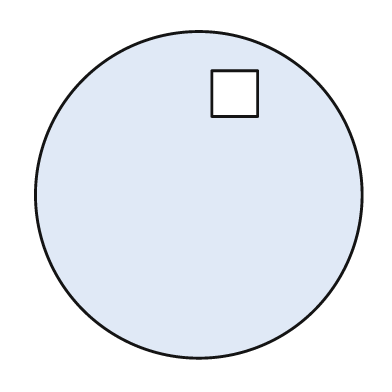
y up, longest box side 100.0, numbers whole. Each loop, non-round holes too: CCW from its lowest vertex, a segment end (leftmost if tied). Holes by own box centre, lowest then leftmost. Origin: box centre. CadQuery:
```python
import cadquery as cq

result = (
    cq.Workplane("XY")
    .moveTo(0.0, 0.0)
    .circle(50.0)
    .moveTo(4.0, 24.0)
    .lineTo(18.0, 24.0)
    .lineTo(18.0, 38.0)
    .lineTo(4.0, 38.0)
    .close()
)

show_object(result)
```